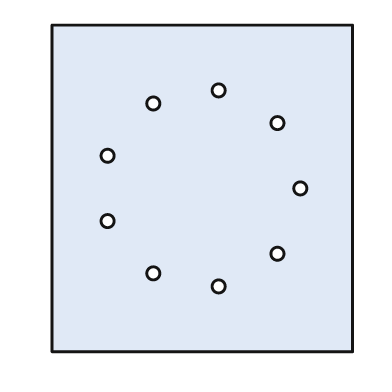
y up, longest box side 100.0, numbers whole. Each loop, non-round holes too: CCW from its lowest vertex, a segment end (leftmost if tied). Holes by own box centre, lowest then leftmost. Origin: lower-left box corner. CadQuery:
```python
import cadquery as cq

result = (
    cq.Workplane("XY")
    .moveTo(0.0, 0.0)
    .lineTo(92.0, 0.0)
    .lineTo(92.0, 100.0)
    .lineTo(0.0, 100.0)
    .close()
    .moveTo(51.0, 20.0)
    .circle(2.0)
    .moveTo(31.0, 24.0)
    .circle(2.0)
    .moveTo(69.0, 30.0)
    .circle(2.0)
    .moveTo(17.0, 40.0)
    .circle(2.0)
    .moveTo(76.0, 50.0)
    .circle(2.0)
    .moveTo(17.0, 60.0)
    .circle(2.0)
    .moveTo(69.0, 70.0)
    .circle(2.0)
    .moveTo(31.0, 76.0)
    .circle(2.0)
    .moveTo(51.0, 80.0)
    .circle(2.0)
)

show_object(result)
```